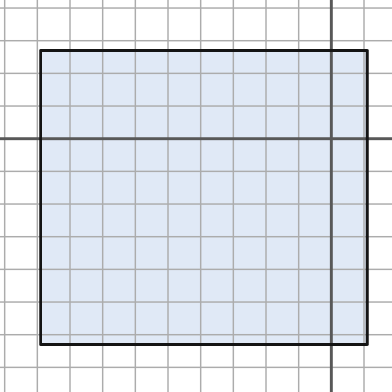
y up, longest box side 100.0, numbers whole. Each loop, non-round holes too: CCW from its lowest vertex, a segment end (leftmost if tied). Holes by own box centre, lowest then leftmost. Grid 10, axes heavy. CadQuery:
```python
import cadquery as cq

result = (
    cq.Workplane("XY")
    .moveTo(-89.0, -63.0)
    .lineTo(11.0, -63.0)
    .lineTo(11.0, 27.0)
    .lineTo(-89.0, 27.0)
    .close()
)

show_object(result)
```